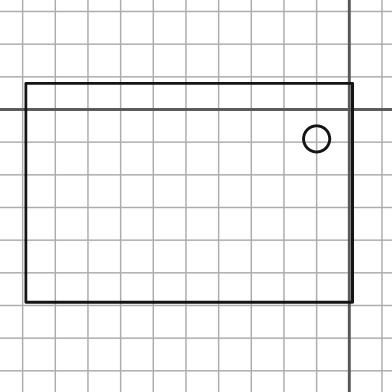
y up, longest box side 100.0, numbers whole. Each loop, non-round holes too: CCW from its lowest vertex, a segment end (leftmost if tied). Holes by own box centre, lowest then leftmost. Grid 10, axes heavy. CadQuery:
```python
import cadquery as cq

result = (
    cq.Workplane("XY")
    .moveTo(-99.0, -59.0)
    .lineTo(1.0, -59.0)
    .lineTo(1.0, 8.0)
    .lineTo(-99.0, 8.0)
    .close()
    .moveTo(-10.0, -9.0)
    .circle(4.0)
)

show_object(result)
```